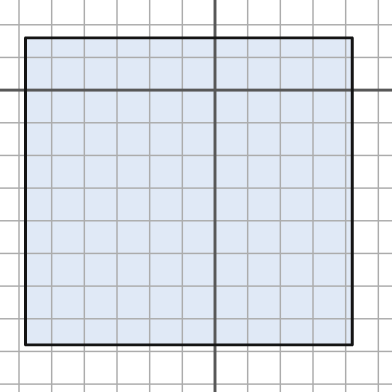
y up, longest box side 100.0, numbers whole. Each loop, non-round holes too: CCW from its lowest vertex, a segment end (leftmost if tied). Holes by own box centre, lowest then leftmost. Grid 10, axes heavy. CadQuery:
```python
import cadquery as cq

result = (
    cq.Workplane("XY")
    .moveTo(-58.0, -78.0)
    .lineTo(42.0, -78.0)
    .lineTo(42.0, 16.0)
    .lineTo(-58.0, 16.0)
    .close()
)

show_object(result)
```